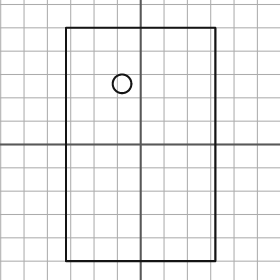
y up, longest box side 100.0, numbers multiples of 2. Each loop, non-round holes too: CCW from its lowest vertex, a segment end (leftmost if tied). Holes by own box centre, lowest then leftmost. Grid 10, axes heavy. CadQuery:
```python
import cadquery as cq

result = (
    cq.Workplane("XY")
    .moveTo(-32.0, -50.0)
    .lineTo(32.0, -50.0)
    .lineTo(32.0, 50.0)
    .lineTo(-32.0, 50.0)
    .close()
    .moveTo(-8.0, 26.0)
    .circle(4.0)
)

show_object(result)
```